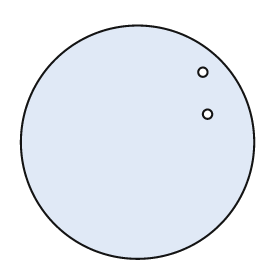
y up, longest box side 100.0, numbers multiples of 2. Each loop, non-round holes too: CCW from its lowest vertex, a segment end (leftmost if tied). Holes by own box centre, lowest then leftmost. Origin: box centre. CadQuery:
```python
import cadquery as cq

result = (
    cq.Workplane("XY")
    .moveTo(0.0, 0.0)
    .circle(50.0)
    .moveTo(30.0, 12.0)
    .circle(2.0)
    .moveTo(28.0, 30.0)
    .circle(2.0)
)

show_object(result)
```